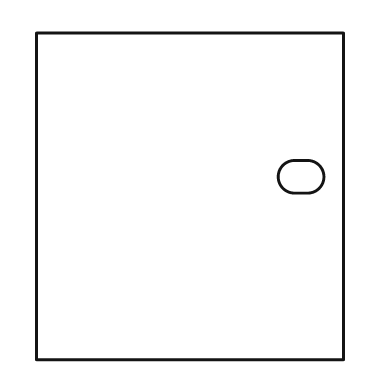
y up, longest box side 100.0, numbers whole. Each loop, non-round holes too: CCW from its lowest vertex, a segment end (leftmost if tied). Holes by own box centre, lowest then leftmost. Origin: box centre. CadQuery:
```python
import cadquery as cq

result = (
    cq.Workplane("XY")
    .moveTo(-47.0, -50.0)
    .lineTo(47.0, -50.0)
    .lineTo(47.0, 50.0)
    .lineTo(-47.0, 50.0)
    .close()
    .moveTo(32.0, 1.0)
    .lineTo(36.0, 1.0)
    .threePointArc((41.0, 6.0), (36.0, 11.0))
    .lineTo(32.0, 11.0)
    .threePointArc((27.0, 6.0), (32.0, 1.0))
    .close()
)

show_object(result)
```